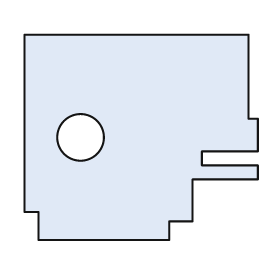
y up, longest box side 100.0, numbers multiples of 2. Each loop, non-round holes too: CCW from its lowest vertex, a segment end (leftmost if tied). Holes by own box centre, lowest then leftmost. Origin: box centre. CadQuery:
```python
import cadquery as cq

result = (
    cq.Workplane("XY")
    .moveTo(-44.0, -44.0)
    .lineTo(12.0, -44.0)
    .lineTo(12.0, -36.0)
    .lineTo(22.0, -36.0)
    .lineTo(22.0, -18.0)
    .lineTo(50.0, -18.0)
    .lineTo(50.0, -12.0)
    .lineTo(26.0, -12.0)
    .lineTo(26.0, -6.0)
    .lineTo(50.0, -6.0)
    .lineTo(50.0, 8.0)
    .lineTo(46.0, 8.0)
    .lineTo(46.0, 44.0)
    .lineTo(-50.0, 44.0)
    .lineTo(-50.0, -32.0)
    .lineTo(-44.0, -32.0)
    .close()
    .moveTo(-26.0, 0.0)
    .circle(10.0)
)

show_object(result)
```